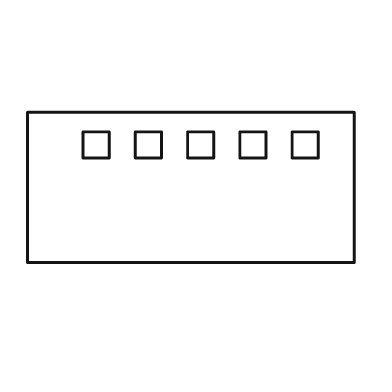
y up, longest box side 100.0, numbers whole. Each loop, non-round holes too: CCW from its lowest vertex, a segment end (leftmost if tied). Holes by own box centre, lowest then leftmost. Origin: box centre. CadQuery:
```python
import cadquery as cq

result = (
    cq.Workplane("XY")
    .moveTo(-50.0, -23.0)
    .lineTo(50.0, -23.0)
    .lineTo(50.0, 23.0)
    .lineTo(-50.0, 23.0)
    .close()
    .moveTo(-33.0, 9.0)
    .lineTo(-25.0, 9.0)
    .lineTo(-25.0, 17.0)
    .lineTo(-33.0, 17.0)
    .close()
    .moveTo(-17.0, 9.0)
    .lineTo(-9.0, 9.0)
    .lineTo(-9.0, 17.0)
    .lineTo(-17.0, 17.0)
    .close()
    .moveTo(-1.0, 9.0)
    .lineTo(7.0, 9.0)
    .lineTo(7.0, 17.0)
    .lineTo(-1.0, 17.0)
    .close()
    .moveTo(15.0, 9.0)
    .lineTo(23.0, 9.0)
    .lineTo(23.0, 17.0)
    .lineTo(15.0, 17.0)
    .close()
    .moveTo(31.0, 9.0)
    .lineTo(39.0, 9.0)
    .lineTo(39.0, 17.0)
    .lineTo(31.0, 17.0)
    .close()
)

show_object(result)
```